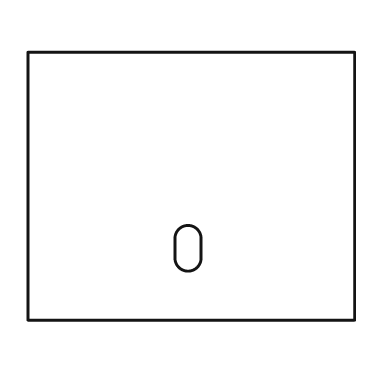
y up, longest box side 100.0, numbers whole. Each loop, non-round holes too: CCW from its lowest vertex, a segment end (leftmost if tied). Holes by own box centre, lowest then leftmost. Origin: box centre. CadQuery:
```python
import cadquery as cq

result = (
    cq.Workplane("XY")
    .moveTo(-50.0, -41.0)
    .lineTo(50.0, -41.0)
    .lineTo(50.0, 41.0)
    .lineTo(-50.0, 41.0)
    .close()
    .moveTo(-5.0, -22.0)
    .threePointArc((-1.0, -26.0), (3.0, -22.0))
    .lineTo(3.0, -16.0)
    .threePointArc((-1.0, -12.0), (-5.0, -16.0))
    .close()
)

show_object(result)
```